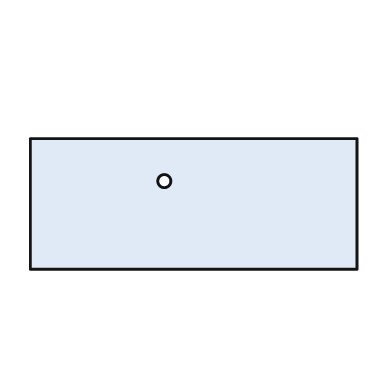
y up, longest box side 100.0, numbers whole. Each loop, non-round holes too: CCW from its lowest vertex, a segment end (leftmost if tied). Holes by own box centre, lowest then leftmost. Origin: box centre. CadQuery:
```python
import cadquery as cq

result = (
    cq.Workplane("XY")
    .moveTo(-50.0, -20.0)
    .lineTo(50.0, -20.0)
    .lineTo(50.0, 20.0)
    .lineTo(-50.0, 20.0)
    .close()
    .moveTo(-9.0, 7.0)
    .circle(2.0)
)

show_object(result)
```